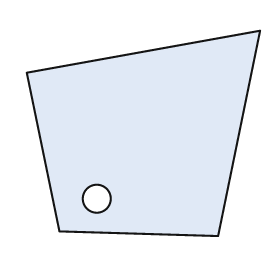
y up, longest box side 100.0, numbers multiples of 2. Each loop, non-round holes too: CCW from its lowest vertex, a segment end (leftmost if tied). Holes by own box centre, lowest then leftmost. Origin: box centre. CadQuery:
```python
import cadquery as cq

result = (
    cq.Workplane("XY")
    .moveTo(32.0, -44.0)
    .lineTo(50.0, 44.0)
    .lineTo(-50.0, 26.0)
    .lineTo(-36.0, -42.0)
    .close()
    .moveTo(-20.0, -28.0)
    .circle(6.0)
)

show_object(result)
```